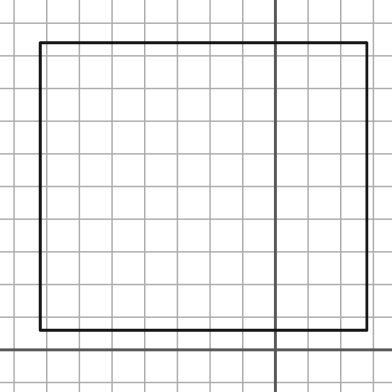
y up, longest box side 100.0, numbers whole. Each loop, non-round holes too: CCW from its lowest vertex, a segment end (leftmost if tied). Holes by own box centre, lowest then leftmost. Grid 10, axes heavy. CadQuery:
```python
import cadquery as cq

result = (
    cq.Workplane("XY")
    .moveTo(-72.0, 6.0)
    .lineTo(28.0, 6.0)
    .lineTo(28.0, 94.0)
    .lineTo(-72.0, 94.0)
    .close()
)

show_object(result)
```